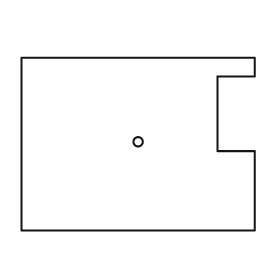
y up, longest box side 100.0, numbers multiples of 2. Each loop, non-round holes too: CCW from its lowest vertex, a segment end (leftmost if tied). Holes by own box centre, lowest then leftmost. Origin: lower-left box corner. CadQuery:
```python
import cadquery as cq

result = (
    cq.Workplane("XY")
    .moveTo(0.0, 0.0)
    .lineTo(100.0, 0.0)
    .lineTo(100.0, 34.0)
    .lineTo(84.0, 34.0)
    .lineTo(84.0, 66.0)
    .lineTo(100.0, 66.0)
    .lineTo(100.0, 74.0)
    .lineTo(0.0, 74.0)
    .close()
    .moveTo(50.0, 38.0)
    .circle(2.0)
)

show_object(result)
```